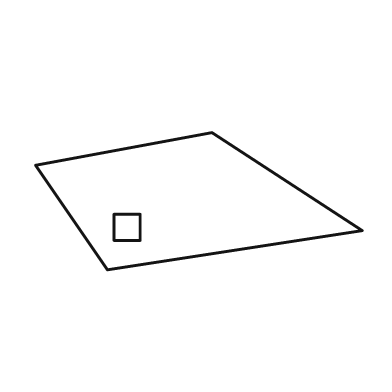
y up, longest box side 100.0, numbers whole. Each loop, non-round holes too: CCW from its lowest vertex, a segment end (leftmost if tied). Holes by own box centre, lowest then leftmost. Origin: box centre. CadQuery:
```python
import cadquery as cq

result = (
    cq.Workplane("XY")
    .moveTo(-28.0, -21.0)
    .lineTo(50.0, -9.0)
    .lineTo(4.0, 21.0)
    .lineTo(-50.0, 11.0)
    .close()
    .moveTo(-26.0, -12.0)
    .lineTo(-18.0, -12.0)
    .lineTo(-18.0, -4.0)
    .lineTo(-26.0, -4.0)
    .close()
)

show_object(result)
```